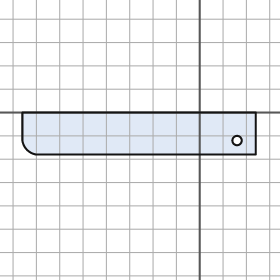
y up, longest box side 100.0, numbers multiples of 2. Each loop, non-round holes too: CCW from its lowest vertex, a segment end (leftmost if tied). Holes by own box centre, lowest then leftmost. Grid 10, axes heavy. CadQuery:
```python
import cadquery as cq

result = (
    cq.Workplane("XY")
    .moveTo(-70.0, -18.0)
    .lineTo(24.0, -18.0)
    .lineTo(24.0, 0.0)
    .lineTo(-76.0, 0.0)
    .lineTo(-76.0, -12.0)
    .threePointArc((-74.0, -16.0), (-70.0, -18.0))
    .close()
    .moveTo(16.0, -12.0)
    .circle(2.0)
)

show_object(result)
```